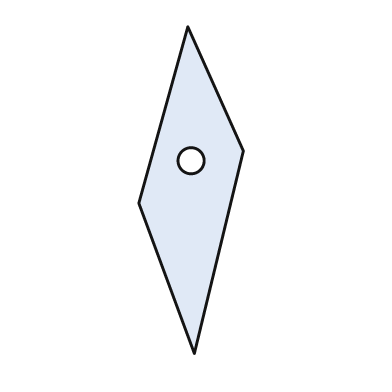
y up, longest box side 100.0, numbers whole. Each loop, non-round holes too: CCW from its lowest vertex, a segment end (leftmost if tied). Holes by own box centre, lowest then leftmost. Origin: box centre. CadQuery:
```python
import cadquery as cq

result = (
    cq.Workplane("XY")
    .moveTo(1.0, -50.0)
    .lineTo(16.0, 12.0)
    .lineTo(-1.0, 50.0)
    .lineTo(-16.0, -4.0)
    .close()
    .moveTo(0.0, 9.0)
    .circle(4.0)
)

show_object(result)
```